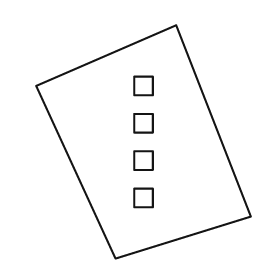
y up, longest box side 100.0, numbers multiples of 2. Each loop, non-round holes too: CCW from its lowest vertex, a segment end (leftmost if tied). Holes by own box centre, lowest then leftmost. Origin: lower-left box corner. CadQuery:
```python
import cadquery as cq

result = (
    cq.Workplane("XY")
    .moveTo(34.0, 0.0)
    .lineTo(92.0, 18.0)
    .lineTo(60.0, 100.0)
    .lineTo(0.0, 74.0)
    .close()
    .moveTo(42.0, 22.0)
    .lineTo(50.0, 22.0)
    .lineTo(50.0, 30.0)
    .lineTo(42.0, 30.0)
    .close()
    .moveTo(42.0, 38.0)
    .lineTo(50.0, 38.0)
    .lineTo(50.0, 46.0)
    .lineTo(42.0, 46.0)
    .close()
    .moveTo(42.0, 54.0)
    .lineTo(50.0, 54.0)
    .lineTo(50.0, 62.0)
    .lineTo(42.0, 62.0)
    .close()
    .moveTo(42.0, 70.0)
    .lineTo(50.0, 70.0)
    .lineTo(50.0, 78.0)
    .lineTo(42.0, 78.0)
    .close()
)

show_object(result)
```